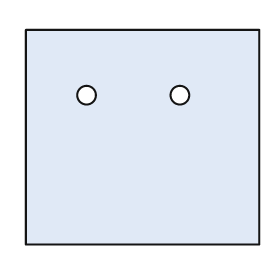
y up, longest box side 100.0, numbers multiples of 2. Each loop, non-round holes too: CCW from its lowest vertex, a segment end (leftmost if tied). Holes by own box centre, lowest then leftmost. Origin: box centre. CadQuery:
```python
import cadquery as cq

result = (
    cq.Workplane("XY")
    .moveTo(-50.0, -46.0)
    .lineTo(50.0, -46.0)
    .lineTo(50.0, 46.0)
    .lineTo(-50.0, 46.0)
    .close()
    .moveTo(-24.0, 18.0)
    .circle(4.0)
    .moveTo(16.0, 18.0)
    .circle(4.0)
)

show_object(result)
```